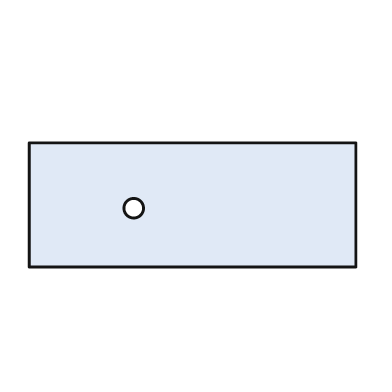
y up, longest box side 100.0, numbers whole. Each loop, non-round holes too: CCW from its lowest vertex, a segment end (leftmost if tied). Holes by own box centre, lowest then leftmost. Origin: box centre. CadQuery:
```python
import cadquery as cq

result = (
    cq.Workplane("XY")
    .moveTo(-50.0, -19.0)
    .lineTo(50.0, -19.0)
    .lineTo(50.0, 19.0)
    .lineTo(-50.0, 19.0)
    .close()
    .moveTo(-18.0, -1.0)
    .circle(3.0)
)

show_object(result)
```